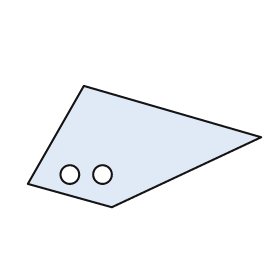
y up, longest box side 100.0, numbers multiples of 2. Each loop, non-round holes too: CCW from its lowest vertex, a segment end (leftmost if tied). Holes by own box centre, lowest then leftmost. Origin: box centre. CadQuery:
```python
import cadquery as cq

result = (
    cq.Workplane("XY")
    .moveTo(-14.0, -26.0)
    .lineTo(50.0, 4.0)
    .lineTo(-26.0, 26.0)
    .lineTo(-50.0, -16.0)
    .close()
    .moveTo(-32.0, -12.0)
    .circle(4.0)
    .moveTo(-18.0, -12.0)
    .circle(4.0)
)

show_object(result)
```